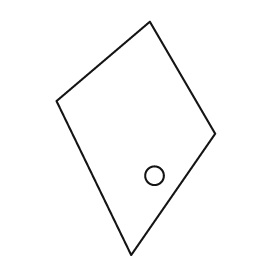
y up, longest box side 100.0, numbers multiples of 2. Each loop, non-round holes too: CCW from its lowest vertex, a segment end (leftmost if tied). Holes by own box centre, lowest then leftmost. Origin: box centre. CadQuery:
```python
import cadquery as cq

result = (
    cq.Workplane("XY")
    .moveTo(-2.0, -50.0)
    .lineTo(34.0, 2.0)
    .lineTo(6.0, 50.0)
    .lineTo(-34.0, 16.0)
    .close()
    .moveTo(8.0, -16.0)
    .circle(4.0)
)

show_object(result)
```